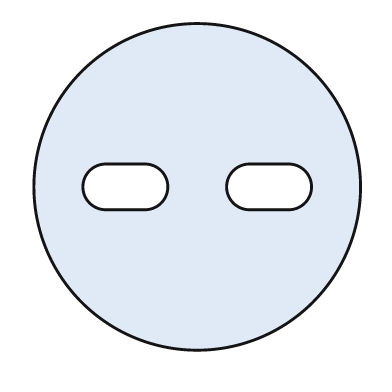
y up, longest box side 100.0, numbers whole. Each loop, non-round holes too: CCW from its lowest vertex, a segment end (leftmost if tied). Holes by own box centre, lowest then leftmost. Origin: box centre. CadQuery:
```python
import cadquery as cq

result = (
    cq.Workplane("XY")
    .moveTo(0.0, 0.0)
    .circle(50.0)
    .moveTo(-28.0, -7.0)
    .lineTo(-16.0, -7.0)
    .threePointArc((-9.0, 0.0), (-16.0, 7.0))
    .lineTo(-28.0, 7.0)
    .threePointArc((-35.0, 0.0), (-28.0, -7.0))
    .close()
    .moveTo(16.0, -7.0)
    .lineTo(28.0, -7.0)
    .threePointArc((35.0, 0.0), (28.0, 7.0))
    .lineTo(16.0, 7.0)
    .threePointArc((9.0, 0.0), (16.0, -7.0))
    .close()
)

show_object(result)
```